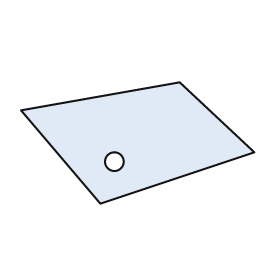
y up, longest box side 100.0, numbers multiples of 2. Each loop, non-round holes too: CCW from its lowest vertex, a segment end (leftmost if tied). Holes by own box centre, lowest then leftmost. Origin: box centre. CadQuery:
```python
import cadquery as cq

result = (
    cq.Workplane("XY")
    .moveTo(-16.0, -26.0)
    .lineTo(50.0, -4.0)
    .lineTo(18.0, 26.0)
    .lineTo(-50.0, 14.0)
    .close()
    .moveTo(-10.0, -8.0)
    .circle(4.0)
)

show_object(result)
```